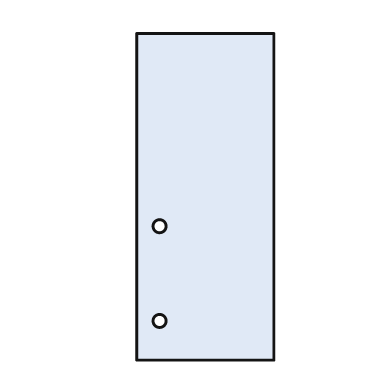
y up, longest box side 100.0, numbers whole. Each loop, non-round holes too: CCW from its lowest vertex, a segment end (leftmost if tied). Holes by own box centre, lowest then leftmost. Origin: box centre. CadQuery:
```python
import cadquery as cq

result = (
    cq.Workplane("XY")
    .moveTo(-21.0, -50.0)
    .lineTo(21.0, -50.0)
    .lineTo(21.0, 50.0)
    .lineTo(-21.0, 50.0)
    .close()
    .moveTo(-14.0, -38.0)
    .circle(2.0)
    .moveTo(-14.0, -9.0)
    .circle(2.0)
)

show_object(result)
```